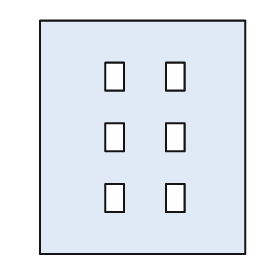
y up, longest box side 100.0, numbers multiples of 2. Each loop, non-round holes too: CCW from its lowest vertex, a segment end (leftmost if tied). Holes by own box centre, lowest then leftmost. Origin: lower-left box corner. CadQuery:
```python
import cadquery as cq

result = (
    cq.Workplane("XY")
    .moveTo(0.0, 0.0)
    .lineTo(88.0, 0.0)
    .lineTo(88.0, 100.0)
    .lineTo(0.0, 100.0)
    .close()
    .moveTo(28.0, 18.0)
    .lineTo(36.0, 18.0)
    .lineTo(36.0, 30.0)
    .lineTo(28.0, 30.0)
    .close()
    .moveTo(54.0, 18.0)
    .lineTo(62.0, 18.0)
    .lineTo(62.0, 30.0)
    .lineTo(54.0, 30.0)
    .close()
    .moveTo(28.0, 44.0)
    .lineTo(36.0, 44.0)
    .lineTo(36.0, 56.0)
    .lineTo(28.0, 56.0)
    .close()
    .moveTo(54.0, 44.0)
    .lineTo(62.0, 44.0)
    .lineTo(62.0, 56.0)
    .lineTo(54.0, 56.0)
    .close()
    .moveTo(28.0, 70.0)
    .lineTo(36.0, 70.0)
    .lineTo(36.0, 82.0)
    .lineTo(28.0, 82.0)
    .close()
    .moveTo(54.0, 70.0)
    .lineTo(62.0, 70.0)
    .lineTo(62.0, 82.0)
    .lineTo(54.0, 82.0)
    .close()
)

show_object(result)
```